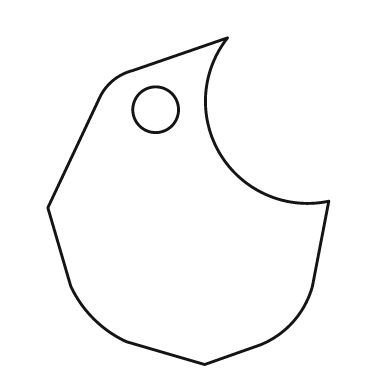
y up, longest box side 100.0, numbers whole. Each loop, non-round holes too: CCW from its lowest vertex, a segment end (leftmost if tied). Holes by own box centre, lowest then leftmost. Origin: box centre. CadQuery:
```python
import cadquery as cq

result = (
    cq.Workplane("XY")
    .moveTo(5.0, -50.0)
    .lineTo(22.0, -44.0)
    .threePointArc((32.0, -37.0), (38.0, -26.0))
    .lineTo(43.0, 0.0)
    .threePointArc((10.0, 14.0), (12.0, 50.0))
    .lineTo(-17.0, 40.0)
    .threePointArc((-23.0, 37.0), (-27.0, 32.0))
    .lineTo(-43.0, -2.0)
    .lineTo(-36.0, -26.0)
    .threePointArc((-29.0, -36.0), (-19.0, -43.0))
    .close()
    .moveTo(-10.0, 28.0)
    .circle(7.0)
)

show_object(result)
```